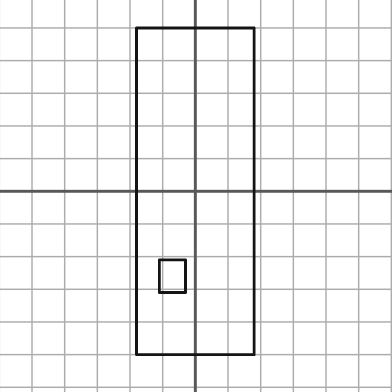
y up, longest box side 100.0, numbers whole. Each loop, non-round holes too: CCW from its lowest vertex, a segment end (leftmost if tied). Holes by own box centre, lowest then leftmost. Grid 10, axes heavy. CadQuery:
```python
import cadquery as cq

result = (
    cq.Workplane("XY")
    .moveTo(-18.0, -50.0)
    .lineTo(18.0, -50.0)
    .lineTo(18.0, 50.0)
    .lineTo(-18.0, 50.0)
    .close()
    .moveTo(-11.0, -31.0)
    .lineTo(-3.0, -31.0)
    .lineTo(-3.0, -21.0)
    .lineTo(-11.0, -21.0)
    .close()
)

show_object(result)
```